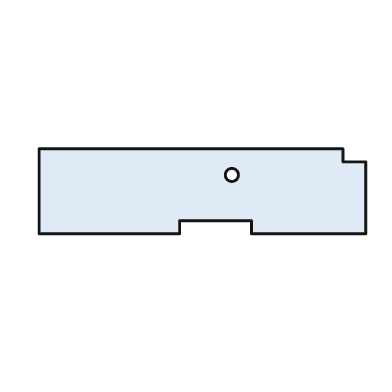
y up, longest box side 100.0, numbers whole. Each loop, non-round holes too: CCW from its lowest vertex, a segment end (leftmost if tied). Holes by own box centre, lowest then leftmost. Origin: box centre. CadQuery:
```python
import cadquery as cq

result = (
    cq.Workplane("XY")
    .moveTo(-50.0, -13.0)
    .lineTo(-7.0, -13.0)
    .lineTo(-7.0, -9.0)
    .lineTo(15.0, -9.0)
    .lineTo(15.0, -13.0)
    .lineTo(50.0, -13.0)
    .lineTo(50.0, 9.0)
    .lineTo(43.0, 9.0)
    .lineTo(43.0, 13.0)
    .lineTo(-50.0, 13.0)
    .close()
    .moveTo(9.0, 5.0)
    .circle(2.0)
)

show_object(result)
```